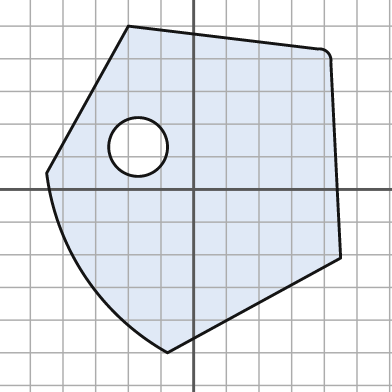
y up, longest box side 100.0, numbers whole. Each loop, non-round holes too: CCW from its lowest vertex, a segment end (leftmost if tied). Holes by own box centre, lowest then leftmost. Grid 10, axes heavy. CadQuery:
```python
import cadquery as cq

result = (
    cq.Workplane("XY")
    .moveTo(-8.0, -50.0)
    .lineTo(45.0, -21.0)
    .lineTo(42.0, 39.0)
    .threePointArc((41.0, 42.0), (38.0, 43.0))
    .lineTo(-20.0, 50.0)
    .lineTo(-45.0, 5.0)
    .threePointArc((-33.0, -27.0), (-8.0, -50.0))
    .close()
    .moveTo(-17.0, 13.0)
    .circle(9.0)
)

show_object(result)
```